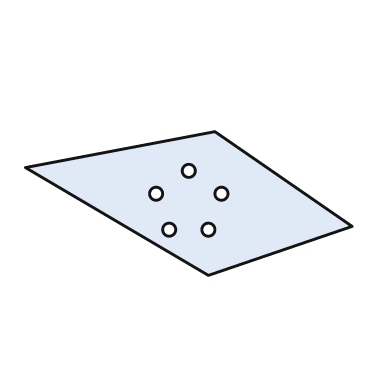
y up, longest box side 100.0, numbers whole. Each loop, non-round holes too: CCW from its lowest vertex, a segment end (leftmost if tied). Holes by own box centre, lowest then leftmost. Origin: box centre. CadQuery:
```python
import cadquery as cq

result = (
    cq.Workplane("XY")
    .moveTo(6.0, -22.0)
    .lineTo(50.0, -7.0)
    .lineTo(8.0, 22.0)
    .lineTo(-50.0, 11.0)
    .close()
    .moveTo(-6.0, -8.0)
    .circle(2.0)
    .moveTo(6.0, -8.0)
    .circle(2.0)
    .moveTo(-10.0, 3.0)
    .circle(2.0)
    .moveTo(10.0, 3.0)
    .circle(2.0)
    .moveTo(0.0, 10.0)
    .circle(2.0)
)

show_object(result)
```